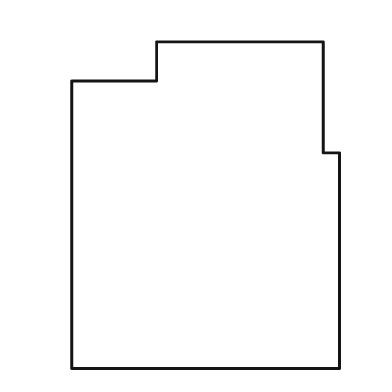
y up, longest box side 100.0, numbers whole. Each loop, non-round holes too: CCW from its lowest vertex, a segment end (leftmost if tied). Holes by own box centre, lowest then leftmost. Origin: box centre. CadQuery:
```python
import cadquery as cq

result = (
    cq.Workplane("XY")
    .moveTo(-41.0, -50.0)
    .lineTo(41.0, -50.0)
    .lineTo(41.0, 16.0)
    .lineTo(36.0, 16.0)
    .lineTo(36.0, 50.0)
    .lineTo(-15.0, 50.0)
    .lineTo(-15.0, 38.0)
    .lineTo(-41.0, 38.0)
    .close()
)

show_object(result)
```